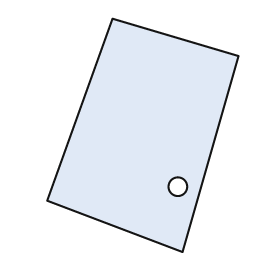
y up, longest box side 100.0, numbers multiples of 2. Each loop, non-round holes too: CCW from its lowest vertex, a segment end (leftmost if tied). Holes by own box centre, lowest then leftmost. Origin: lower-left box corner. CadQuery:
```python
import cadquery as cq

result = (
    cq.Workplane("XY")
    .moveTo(58.0, 0.0)
    .lineTo(82.0, 84.0)
    .lineTo(28.0, 100.0)
    .lineTo(0.0, 22.0)
    .close()
    .moveTo(56.0, 28.0)
    .circle(4.0)
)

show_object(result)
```